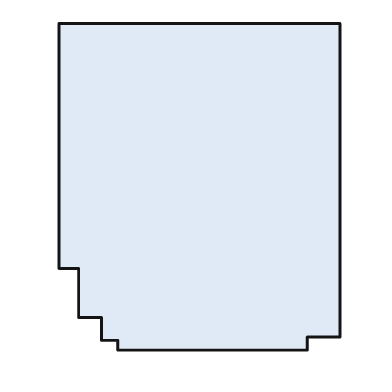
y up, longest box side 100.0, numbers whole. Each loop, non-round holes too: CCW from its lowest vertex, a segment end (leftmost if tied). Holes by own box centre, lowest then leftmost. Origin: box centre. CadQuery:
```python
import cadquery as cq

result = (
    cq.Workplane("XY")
    .moveTo(-25.0, -50.0)
    .lineTo(33.0, -50.0)
    .lineTo(33.0, -46.0)
    .lineTo(43.0, -46.0)
    .lineTo(43.0, 50.0)
    .lineTo(-43.0, 50.0)
    .lineTo(-43.0, -25.0)
    .lineTo(-37.0, -25.0)
    .lineTo(-37.0, -40.0)
    .lineTo(-30.0, -40.0)
    .lineTo(-30.0, -47.0)
    .lineTo(-25.0, -47.0)
    .close()
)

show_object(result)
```